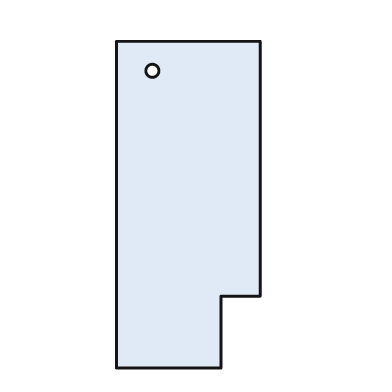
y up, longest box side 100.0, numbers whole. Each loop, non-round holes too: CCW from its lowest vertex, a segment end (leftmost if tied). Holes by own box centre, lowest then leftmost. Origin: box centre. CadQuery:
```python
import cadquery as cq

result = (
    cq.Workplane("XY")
    .moveTo(-22.0, -50.0)
    .lineTo(10.0, -50.0)
    .lineTo(10.0, -28.0)
    .lineTo(22.0, -28.0)
    .lineTo(22.0, 50.0)
    .lineTo(-22.0, 50.0)
    .close()
    .moveTo(-11.0, 41.0)
    .circle(2.0)
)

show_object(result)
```